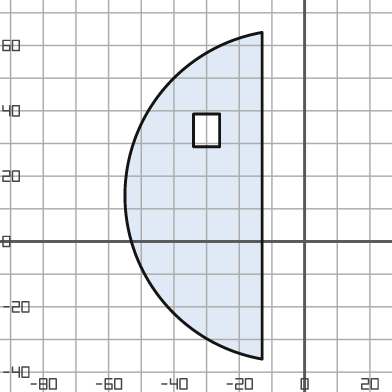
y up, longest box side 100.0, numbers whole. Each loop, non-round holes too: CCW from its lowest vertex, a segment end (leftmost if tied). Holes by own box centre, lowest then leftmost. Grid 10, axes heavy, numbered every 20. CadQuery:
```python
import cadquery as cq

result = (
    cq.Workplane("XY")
    .moveTo(-13.0, -36.0)
    .lineTo(-13.0, 64.0)
    .threePointArc((-55.0, 14.0), (-13.0, -36.0))
    .close()
    .moveTo(-34.0, 29.0)
    .lineTo(-26.0, 29.0)
    .lineTo(-26.0, 39.0)
    .lineTo(-34.0, 39.0)
    .close()
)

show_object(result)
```